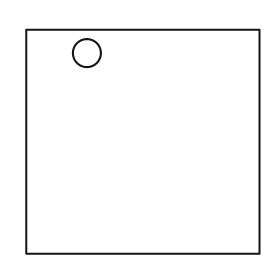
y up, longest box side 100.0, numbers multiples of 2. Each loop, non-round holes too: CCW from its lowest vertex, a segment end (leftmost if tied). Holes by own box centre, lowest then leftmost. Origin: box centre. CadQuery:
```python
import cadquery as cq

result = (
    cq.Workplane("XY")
    .moveTo(-50.0, -48.0)
    .lineTo(50.0, -48.0)
    .lineTo(50.0, 48.0)
    .lineTo(-50.0, 48.0)
    .close()
    .moveTo(-24.0, 38.0)
    .circle(6.0)
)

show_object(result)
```